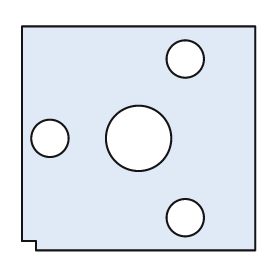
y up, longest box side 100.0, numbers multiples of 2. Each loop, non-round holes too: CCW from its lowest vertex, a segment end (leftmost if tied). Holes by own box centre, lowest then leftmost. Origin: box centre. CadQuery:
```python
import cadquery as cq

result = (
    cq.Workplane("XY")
    .moveTo(-44.0, -48.0)
    .lineTo(50.0, -48.0)
    .lineTo(50.0, 48.0)
    .lineTo(-50.0, 48.0)
    .lineTo(-50.0, -44.0)
    .lineTo(-44.0, -44.0)
    .close()
    .moveTo(20.0, -34.0)
    .circle(8.0)
    .moveTo(-38.0, 0.0)
    .circle(8.0)
    .moveTo(0.0, 0.0)
    .circle(14.0)
    .moveTo(20.0, 34.0)
    .circle(8.0)
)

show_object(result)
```